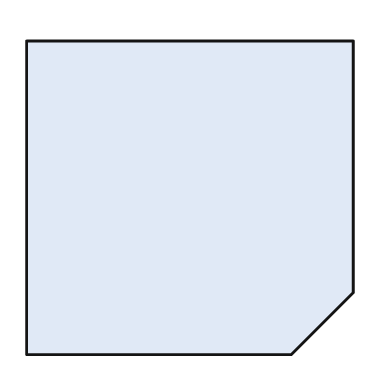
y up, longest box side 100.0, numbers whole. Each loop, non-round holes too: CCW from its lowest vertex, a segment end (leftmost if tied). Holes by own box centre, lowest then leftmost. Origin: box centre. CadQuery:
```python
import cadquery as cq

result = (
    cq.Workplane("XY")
    .moveTo(-50.0, -48.0)
    .lineTo(31.0, -48.0)
    .lineTo(50.0, -29.0)
    .lineTo(50.0, 48.0)
    .lineTo(-50.0, 48.0)
    .close()
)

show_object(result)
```